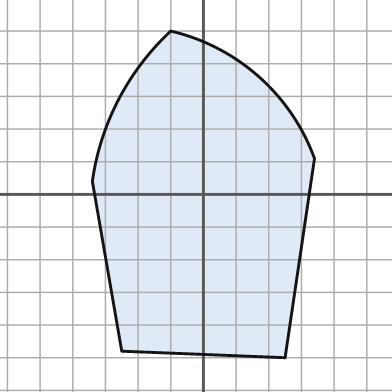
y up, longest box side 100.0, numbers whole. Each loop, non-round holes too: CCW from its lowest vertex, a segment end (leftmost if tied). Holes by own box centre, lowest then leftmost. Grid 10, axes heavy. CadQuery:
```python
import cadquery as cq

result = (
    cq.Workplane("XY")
    .moveTo(25.0, -50.0)
    .lineTo(34.0, 11.0)
    .threePointArc((17.0, 36.0), (-10.0, 50.0))
    .threePointArc((-26.0, 29.0), (-34.0, 4.0))
    .lineTo(-25.0, -48.0)
    .close()
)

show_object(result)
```